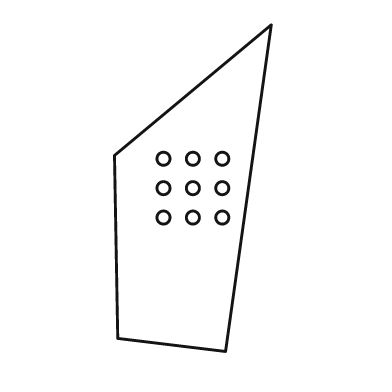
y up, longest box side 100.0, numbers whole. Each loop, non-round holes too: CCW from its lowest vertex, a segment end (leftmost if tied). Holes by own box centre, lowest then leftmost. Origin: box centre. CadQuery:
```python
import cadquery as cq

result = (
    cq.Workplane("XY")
    .moveTo(10.0, -50.0)
    .lineTo(24.0, 50.0)
    .lineTo(-24.0, 10.0)
    .lineTo(-23.0, -46.0)
    .close()
    .moveTo(-9.0, -9.0)
    .circle(2.0)
    .moveTo(0.0, -9.0)
    .circle(2.0)
    .moveTo(9.0, -9.0)
    .circle(2.0)
    .moveTo(-9.0, 0.0)
    .circle(2.0)
    .moveTo(0.0, 0.0)
    .circle(2.0)
    .moveTo(9.0, 0.0)
    .circle(2.0)
    .moveTo(-9.0, 9.0)
    .circle(2.0)
    .moveTo(0.0, 9.0)
    .circle(2.0)
    .moveTo(9.0, 9.0)
    .circle(2.0)
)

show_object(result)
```